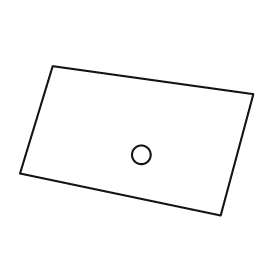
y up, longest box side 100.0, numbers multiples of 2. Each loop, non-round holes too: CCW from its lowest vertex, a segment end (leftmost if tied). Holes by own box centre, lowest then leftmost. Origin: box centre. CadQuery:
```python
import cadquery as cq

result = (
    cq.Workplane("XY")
    .moveTo(36.0, -32.0)
    .lineTo(50.0, 20.0)
    .lineTo(-36.0, 32.0)
    .lineTo(-50.0, -14.0)
    .close()
    .moveTo(2.0, -6.0)
    .circle(4.0)
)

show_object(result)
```